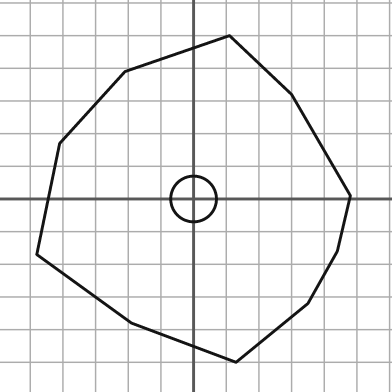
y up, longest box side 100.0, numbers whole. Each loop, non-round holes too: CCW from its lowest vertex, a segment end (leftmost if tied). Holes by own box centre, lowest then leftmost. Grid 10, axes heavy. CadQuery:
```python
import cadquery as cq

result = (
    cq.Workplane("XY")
    .moveTo(13.0, -50.0)
    .lineTo(35.0, -32.0)
    .lineTo(44.0, -16.0)
    .lineTo(48.0, 1.0)
    .lineTo(30.0, 32.0)
    .lineTo(11.0, 50.0)
    .lineTo(-21.0, 39.0)
    .lineTo(-41.0, 17.0)
    .lineTo(-48.0, -17.0)
    .lineTo(-19.0, -38.0)
    .close()
    .moveTo(0.0, 0.0)
    .circle(7.0)
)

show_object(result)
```